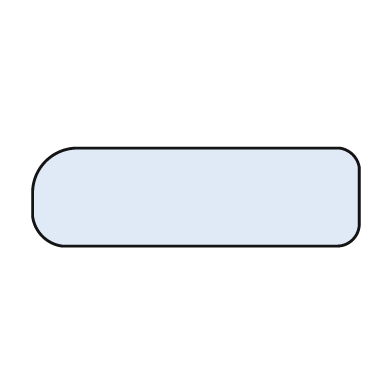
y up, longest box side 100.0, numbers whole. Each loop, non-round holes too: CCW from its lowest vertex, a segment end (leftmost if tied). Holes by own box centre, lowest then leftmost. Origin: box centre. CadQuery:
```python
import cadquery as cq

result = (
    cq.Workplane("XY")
    .moveTo(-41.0, -15.0)
    .lineTo(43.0, -15.0)
    .threePointArc((48.0, -13.0), (50.0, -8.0))
    .lineTo(50.0, 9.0)
    .threePointArc((48.0, 13.0), (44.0, 15.0))
    .lineTo(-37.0, 15.0)
    .threePointArc((-46.0, 11.0), (-50.0, 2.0))
    .lineTo(-50.0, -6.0)
    .threePointArc((-47.0, -12.0), (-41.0, -15.0))
    .close()
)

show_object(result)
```